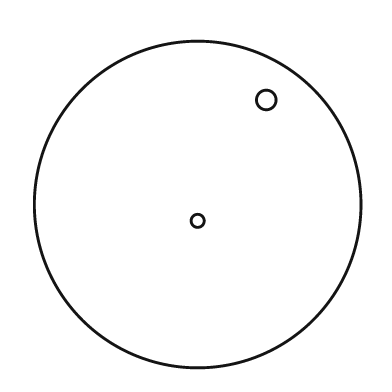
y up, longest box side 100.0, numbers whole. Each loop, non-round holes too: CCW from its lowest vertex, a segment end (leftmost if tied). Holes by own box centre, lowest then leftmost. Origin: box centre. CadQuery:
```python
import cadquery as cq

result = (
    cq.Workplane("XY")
    .moveTo(0.0, 0.0)
    .circle(50.0)
    .moveTo(0.0, -5.0)
    .circle(2.0)
    .moveTo(21.0, 32.0)
    .circle(3.0)
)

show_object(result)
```